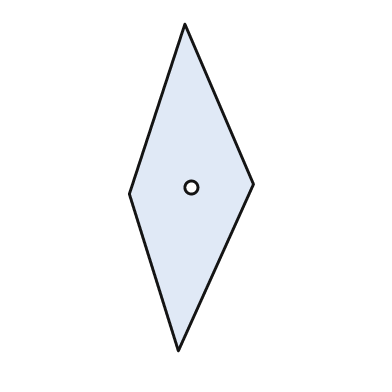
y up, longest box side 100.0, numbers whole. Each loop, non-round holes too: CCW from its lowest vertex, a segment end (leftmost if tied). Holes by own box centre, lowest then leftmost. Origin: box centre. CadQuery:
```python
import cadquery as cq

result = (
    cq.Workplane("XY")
    .moveTo(-4.0, -50.0)
    .lineTo(19.0, 1.0)
    .lineTo(-2.0, 50.0)
    .lineTo(-19.0, -2.0)
    .close()
    .moveTo(0.0, 0.0)
    .circle(2.0)
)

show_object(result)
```